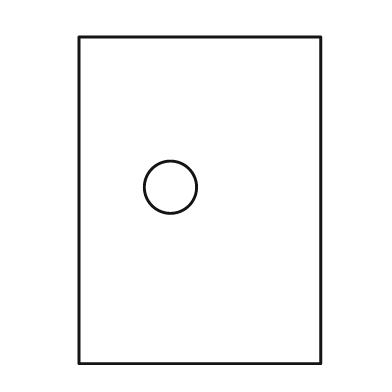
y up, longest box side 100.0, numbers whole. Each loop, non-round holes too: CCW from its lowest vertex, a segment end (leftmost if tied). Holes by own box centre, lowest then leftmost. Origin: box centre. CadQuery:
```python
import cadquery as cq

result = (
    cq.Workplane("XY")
    .moveTo(-37.0, -50.0)
    .lineTo(37.0, -50.0)
    .lineTo(37.0, 50.0)
    .lineTo(-37.0, 50.0)
    .close()
    .moveTo(-9.0, 4.0)
    .circle(8.0)
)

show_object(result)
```